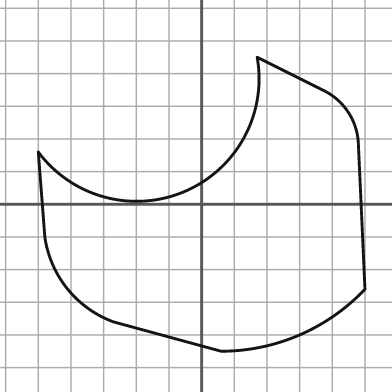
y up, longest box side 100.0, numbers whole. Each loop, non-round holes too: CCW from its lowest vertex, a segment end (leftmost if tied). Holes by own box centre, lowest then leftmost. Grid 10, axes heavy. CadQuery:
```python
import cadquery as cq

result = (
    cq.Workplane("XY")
    .moveTo(6.0, -45.0)
    .threePointArc((30.0, -40.0), (50.0, -26.0))
    .lineTo(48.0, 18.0)
    .threePointArc((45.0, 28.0), (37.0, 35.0))
    .lineTo(17.0, 45.0)
    .threePointArc((-5.0, 4.0), (-50.0, 16.0))
    .lineTo(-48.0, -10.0)
    .threePointArc((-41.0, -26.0), (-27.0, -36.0))
    .close()
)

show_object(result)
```